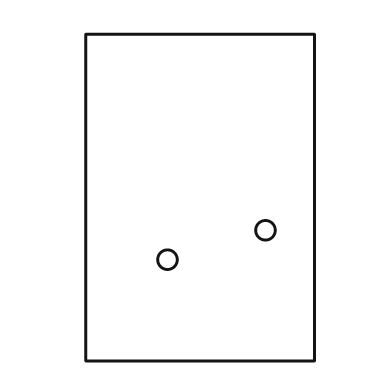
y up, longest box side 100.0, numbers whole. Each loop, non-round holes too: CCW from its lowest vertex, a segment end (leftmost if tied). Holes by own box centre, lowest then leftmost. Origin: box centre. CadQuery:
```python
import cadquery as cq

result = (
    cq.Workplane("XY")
    .moveTo(-35.0, -50.0)
    .lineTo(35.0, -50.0)
    .lineTo(35.0, 50.0)
    .lineTo(-35.0, 50.0)
    .close()
    .moveTo(-10.0, -19.0)
    .circle(3.0)
    .moveTo(20.0, -10.0)
    .circle(3.0)
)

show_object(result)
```